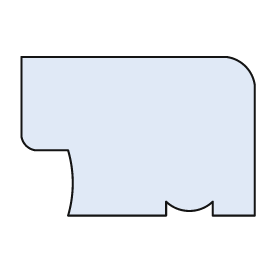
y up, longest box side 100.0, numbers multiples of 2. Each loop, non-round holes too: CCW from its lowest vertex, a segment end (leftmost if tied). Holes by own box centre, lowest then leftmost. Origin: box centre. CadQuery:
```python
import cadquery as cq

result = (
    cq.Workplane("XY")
    .moveTo(-30.0, -34.0)
    .lineTo(12.0, -34.0)
    .lineTo(12.0, -28.0)
    .threePointArc((22.0, -32.0), (32.0, -28.0))
    .lineTo(32.0, -34.0)
    .lineTo(50.0, -34.0)
    .lineTo(50.0, 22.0)
    .threePointArc((46.0, 30.0), (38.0, 34.0))
    .lineTo(-50.0, 34.0)
    .lineTo(-50.0, 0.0)
    .threePointArc((-48.0, -4.0), (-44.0, -6.0))
    .lineTo(-30.0, -6.0)
    .threePointArc((-28.0, -20.0), (-30.0, -34.0))
    .close()
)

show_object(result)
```